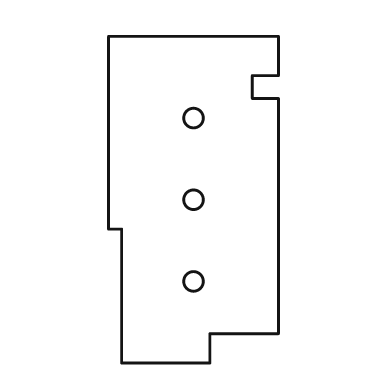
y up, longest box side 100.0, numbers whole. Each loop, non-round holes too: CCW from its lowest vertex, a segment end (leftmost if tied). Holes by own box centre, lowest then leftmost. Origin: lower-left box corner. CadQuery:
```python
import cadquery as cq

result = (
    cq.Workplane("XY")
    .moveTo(4.0, 0.0)
    .lineTo(31.0, 0.0)
    .lineTo(31.0, 9.0)
    .lineTo(52.0, 9.0)
    .lineTo(52.0, 81.0)
    .lineTo(44.0, 81.0)
    .lineTo(44.0, 88.0)
    .lineTo(52.0, 88.0)
    .lineTo(52.0, 100.0)
    .lineTo(0.0, 100.0)
    .lineTo(0.0, 41.0)
    .lineTo(4.0, 41.0)
    .close()
    .moveTo(26.0, 25.0)
    .circle(3.0)
    .moveTo(26.0, 50.0)
    .circle(3.0)
    .moveTo(26.0, 75.0)
    .circle(3.0)
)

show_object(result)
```